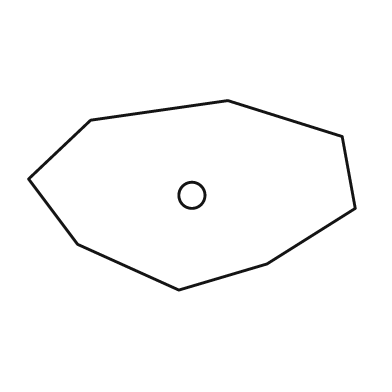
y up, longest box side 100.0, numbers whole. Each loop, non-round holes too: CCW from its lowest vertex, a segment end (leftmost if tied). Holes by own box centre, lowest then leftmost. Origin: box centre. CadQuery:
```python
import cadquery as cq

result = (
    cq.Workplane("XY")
    .moveTo(-4.0, -29.0)
    .lineTo(23.0, -21.0)
    .lineTo(50.0, -4.0)
    .lineTo(46.0, 18.0)
    .lineTo(11.0, 29.0)
    .lineTo(-31.0, 23.0)
    .lineTo(-50.0, 5.0)
    .lineTo(-35.0, -15.0)
    .close()
    .moveTo(0.0, 0.0)
    .circle(4.0)
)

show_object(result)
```